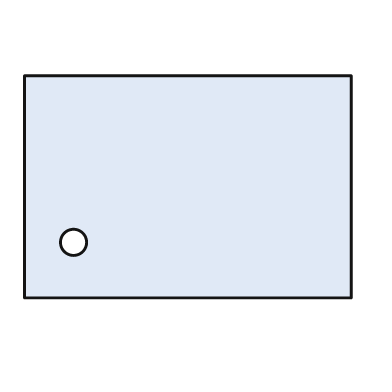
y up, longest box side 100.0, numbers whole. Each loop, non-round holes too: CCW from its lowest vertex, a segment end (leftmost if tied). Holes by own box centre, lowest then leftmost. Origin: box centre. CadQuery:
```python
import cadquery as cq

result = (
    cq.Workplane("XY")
    .moveTo(-50.0, -34.0)
    .lineTo(50.0, -34.0)
    .lineTo(50.0, 34.0)
    .lineTo(-50.0, 34.0)
    .close()
    .moveTo(-35.0, -17.0)
    .circle(4.0)
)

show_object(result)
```